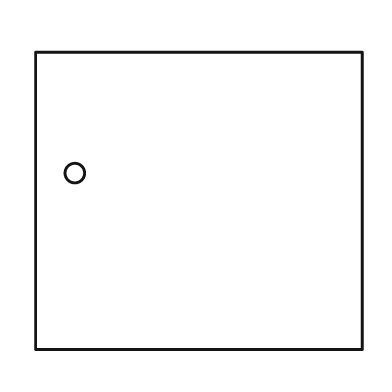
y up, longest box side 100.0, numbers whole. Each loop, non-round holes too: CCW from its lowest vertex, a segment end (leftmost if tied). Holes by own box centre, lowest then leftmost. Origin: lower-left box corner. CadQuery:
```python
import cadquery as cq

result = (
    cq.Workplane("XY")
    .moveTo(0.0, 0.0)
    .lineTo(100.0, 0.0)
    .lineTo(100.0, 91.0)
    .lineTo(0.0, 91.0)
    .close()
    .moveTo(12.0, 54.0)
    .circle(3.0)
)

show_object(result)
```